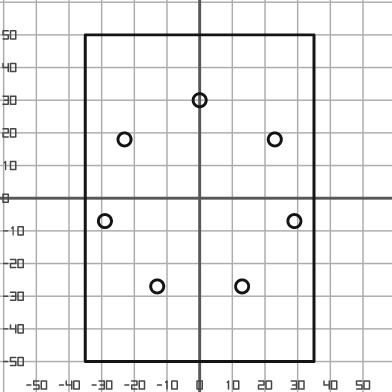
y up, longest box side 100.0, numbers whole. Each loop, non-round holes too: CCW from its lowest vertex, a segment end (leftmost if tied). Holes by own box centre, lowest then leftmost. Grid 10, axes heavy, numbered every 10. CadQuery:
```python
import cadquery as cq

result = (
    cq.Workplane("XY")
    .moveTo(-35.0, -50.0)
    .lineTo(35.0, -50.0)
    .lineTo(35.0, 50.0)
    .lineTo(-35.0, 50.0)
    .close()
    .moveTo(-13.0, -27.0)
    .circle(2.0)
    .moveTo(13.0, -27.0)
    .circle(2.0)
    .moveTo(-29.0, -7.0)
    .circle(2.0)
    .moveTo(29.0, -7.0)
    .circle(2.0)
    .moveTo(-23.0, 18.0)
    .circle(2.0)
    .moveTo(23.0, 18.0)
    .circle(2.0)
    .moveTo(0.0, 30.0)
    .circle(2.0)
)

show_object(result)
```